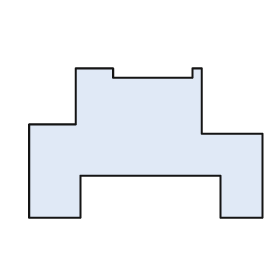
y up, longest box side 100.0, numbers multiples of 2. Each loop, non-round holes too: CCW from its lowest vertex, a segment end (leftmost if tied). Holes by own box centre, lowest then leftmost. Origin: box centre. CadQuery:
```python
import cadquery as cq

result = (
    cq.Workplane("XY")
    .moveTo(-50.0, -32.0)
    .lineTo(-28.0, -32.0)
    .lineTo(-28.0, -14.0)
    .lineTo(32.0, -14.0)
    .lineTo(32.0, -32.0)
    .lineTo(50.0, -32.0)
    .lineTo(50.0, 4.0)
    .lineTo(24.0, 4.0)
    .lineTo(24.0, 32.0)
    .lineTo(20.0, 32.0)
    .lineTo(20.0, 28.0)
    .lineTo(-14.0, 28.0)
    .lineTo(-14.0, 32.0)
    .lineTo(-30.0, 32.0)
    .lineTo(-30.0, 8.0)
    .lineTo(-50.0, 8.0)
    .close()
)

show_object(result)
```